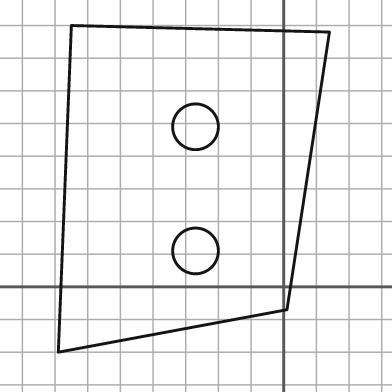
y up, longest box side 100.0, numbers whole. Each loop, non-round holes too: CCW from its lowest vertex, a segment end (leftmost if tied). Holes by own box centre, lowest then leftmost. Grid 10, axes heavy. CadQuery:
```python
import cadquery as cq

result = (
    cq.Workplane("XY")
    .moveTo(-69.0, -20.0)
    .lineTo(1.0, -7.0)
    .lineTo(14.0, 78.0)
    .lineTo(-65.0, 80.0)
    .close()
    .moveTo(-27.0, 11.0)
    .circle(7.0)
    .moveTo(-27.0, 49.0)
    .circle(7.0)
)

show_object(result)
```